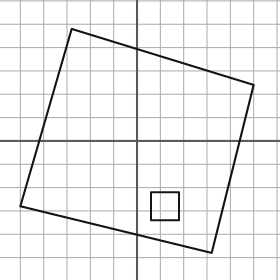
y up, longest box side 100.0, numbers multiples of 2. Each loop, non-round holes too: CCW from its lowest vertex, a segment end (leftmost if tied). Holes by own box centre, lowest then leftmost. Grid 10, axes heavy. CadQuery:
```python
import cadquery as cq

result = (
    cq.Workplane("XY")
    .moveTo(32.0, -48.0)
    .lineTo(50.0, 24.0)
    .lineTo(-28.0, 48.0)
    .lineTo(-50.0, -28.0)
    .close()
    .moveTo(6.0, -34.0)
    .lineTo(18.0, -34.0)
    .lineTo(18.0, -22.0)
    .lineTo(6.0, -22.0)
    .close()
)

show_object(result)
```